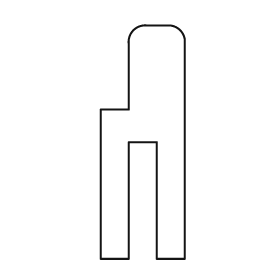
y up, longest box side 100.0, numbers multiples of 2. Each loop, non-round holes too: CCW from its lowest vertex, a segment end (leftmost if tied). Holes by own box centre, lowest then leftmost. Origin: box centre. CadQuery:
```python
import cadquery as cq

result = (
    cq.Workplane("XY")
    .moveTo(-18.0, -50.0)
    .lineTo(-6.0, -50.0)
    .lineTo(-6.0, 0.0)
    .lineTo(6.0, 0.0)
    .lineTo(6.0, -50.0)
    .lineTo(18.0, -50.0)
    .lineTo(18.0, 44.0)
    .threePointArc((16.0, 48.0), (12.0, 50.0))
    .lineTo(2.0, 50.0)
    .threePointArc((-4.0, 48.0), (-6.0, 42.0))
    .lineTo(-6.0, 14.0)
    .lineTo(-18.0, 14.0)
    .close()
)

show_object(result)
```